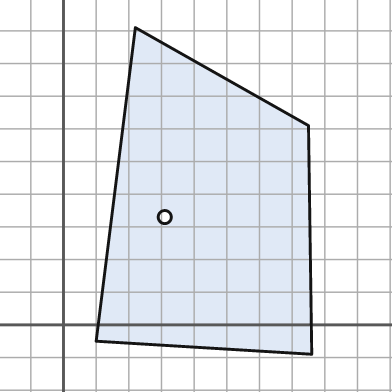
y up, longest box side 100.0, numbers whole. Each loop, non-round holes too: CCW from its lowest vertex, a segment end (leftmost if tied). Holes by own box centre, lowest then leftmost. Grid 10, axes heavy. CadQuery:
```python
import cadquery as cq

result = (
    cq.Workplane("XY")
    .moveTo(76.0, -9.0)
    .lineTo(75.0, 61.0)
    .lineTo(22.0, 91.0)
    .lineTo(10.0, -5.0)
    .close()
    .moveTo(31.0, 33.0)
    .circle(2.0)
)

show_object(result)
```